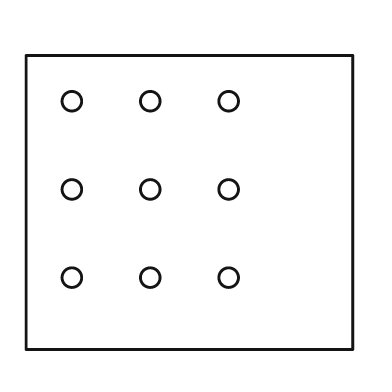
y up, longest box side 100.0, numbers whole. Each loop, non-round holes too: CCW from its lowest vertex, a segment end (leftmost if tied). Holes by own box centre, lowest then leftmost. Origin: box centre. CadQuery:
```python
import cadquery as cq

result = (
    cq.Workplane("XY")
    .moveTo(-50.0, -45.0)
    .lineTo(50.0, -45.0)
    .lineTo(50.0, 45.0)
    .lineTo(-50.0, 45.0)
    .close()
    .moveTo(-36.0, -23.0)
    .circle(3.0)
    .moveTo(-12.0, -23.0)
    .circle(3.0)
    .moveTo(12.0, -23.0)
    .circle(3.0)
    .moveTo(-36.0, 4.0)
    .circle(3.0)
    .moveTo(-12.0, 4.0)
    .circle(3.0)
    .moveTo(12.0, 4.0)
    .circle(3.0)
    .moveTo(-36.0, 31.0)
    .circle(3.0)
    .moveTo(-12.0, 31.0)
    .circle(3.0)
    .moveTo(12.0, 31.0)
    .circle(3.0)
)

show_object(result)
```